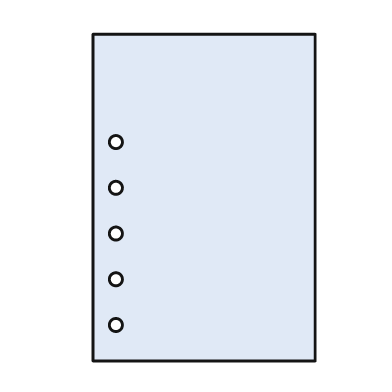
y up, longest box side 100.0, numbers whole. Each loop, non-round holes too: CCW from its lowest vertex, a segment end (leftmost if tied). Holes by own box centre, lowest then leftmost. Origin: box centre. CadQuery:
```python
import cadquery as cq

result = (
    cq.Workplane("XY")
    .moveTo(-34.0, -50.0)
    .lineTo(34.0, -50.0)
    .lineTo(34.0, 50.0)
    .lineTo(-34.0, 50.0)
    .close()
    .moveTo(-27.0, -39.0)
    .circle(2.0)
    .moveTo(-27.0, -25.0)
    .circle(2.0)
    .moveTo(-27.0, -11.0)
    .circle(2.0)
    .moveTo(-27.0, 3.0)
    .circle(2.0)
    .moveTo(-27.0, 17.0)
    .circle(2.0)
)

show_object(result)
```